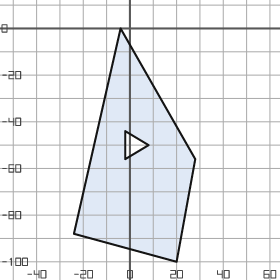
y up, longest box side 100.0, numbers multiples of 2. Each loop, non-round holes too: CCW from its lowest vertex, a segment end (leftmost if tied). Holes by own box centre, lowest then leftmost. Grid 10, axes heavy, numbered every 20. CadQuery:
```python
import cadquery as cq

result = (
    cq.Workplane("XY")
    .moveTo(20.0, -100.0)
    .lineTo(28.0, -56.0)
    .lineTo(-4.0, 0.0)
    .lineTo(-24.0, -88.0)
    .close()
    .moveTo(-2.0, -56.0)
    .lineTo(8.0, -50.0)
    .lineTo(-2.0, -44.0)
    .close()
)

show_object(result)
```